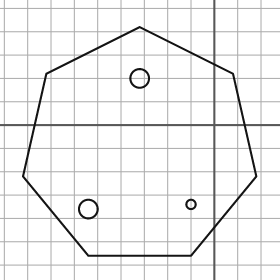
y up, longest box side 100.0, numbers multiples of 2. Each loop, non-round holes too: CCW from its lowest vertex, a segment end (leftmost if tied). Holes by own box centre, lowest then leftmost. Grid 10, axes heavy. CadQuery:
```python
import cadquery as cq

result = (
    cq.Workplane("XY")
    .moveTo(-54.0, -56.0)
    .lineTo(-10.0, -56.0)
    .lineTo(18.0, -22.0)
    .lineTo(8.0, 22.0)
    .lineTo(-32.0, 42.0)
    .lineTo(-72.0, 22.0)
    .lineTo(-82.0, -22.0)
    .close()
    .moveTo(-54.0, -36.0)
    .circle(4.0)
    .moveTo(-10.0, -34.0)
    .circle(2.0)
    .moveTo(-32.0, 20.0)
    .circle(4.0)
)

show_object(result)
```